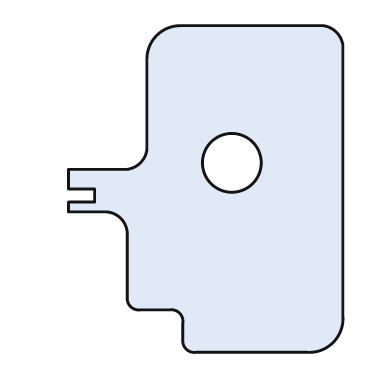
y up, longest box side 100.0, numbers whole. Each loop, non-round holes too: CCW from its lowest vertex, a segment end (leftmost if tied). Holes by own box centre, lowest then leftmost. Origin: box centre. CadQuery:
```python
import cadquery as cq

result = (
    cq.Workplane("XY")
    .moveTo(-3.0, -50.0)
    .lineTo(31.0, -50.0)
    .threePointArc((39.0, -47.0), (42.0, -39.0))
    .lineTo(42.0, 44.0)
    .threePointArc((40.0, 48.0), (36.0, 50.0))
    .lineTo(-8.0, 50.0)
    .threePointArc((-15.0, 47.0), (-18.0, 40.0))
    .lineTo(-18.0, 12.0)
    .threePointArc((-20.0, 8.0), (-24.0, 6.0))
    .lineTo(-42.0, 6.0)
    .lineTo(-42.0, 0.0)
    .lineTo(-34.0, 0.0)
    .lineTo(-34.0, -4.0)
    .lineTo(-42.0, -4.0)
    .lineTo(-42.0, -7.0)
    .lineTo(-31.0, -7.0)
    .threePointArc((-26.0, -9.0), (-24.0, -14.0))
    .lineTo(-24.0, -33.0)
    .threePointArc((-23.0, -36.0), (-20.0, -37.0))
    .lineTo(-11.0, -37.0)
    .threePointArc((-8.0, -38.0), (-7.0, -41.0))
    .lineTo(-7.0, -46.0)
    .threePointArc((-6.0, -49.0), (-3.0, -50.0))
    .close()
    .moveTo(8.0, 8.0)
    .circle(9.0)
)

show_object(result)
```